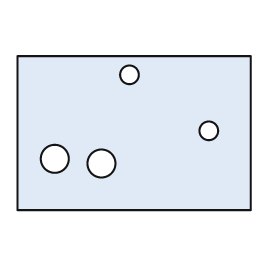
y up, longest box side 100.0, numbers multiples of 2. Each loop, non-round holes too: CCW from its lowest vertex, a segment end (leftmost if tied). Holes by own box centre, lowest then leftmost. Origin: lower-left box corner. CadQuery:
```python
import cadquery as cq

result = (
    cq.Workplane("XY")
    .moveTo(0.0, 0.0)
    .lineTo(100.0, 0.0)
    .lineTo(100.0, 66.0)
    .lineTo(0.0, 66.0)
    .close()
    .moveTo(36.0, 20.0)
    .circle(6.0)
    .moveTo(16.0, 22.0)
    .circle(6.0)
    .moveTo(82.0, 34.0)
    .circle(4.0)
    .moveTo(48.0, 58.0)
    .circle(4.0)
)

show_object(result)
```